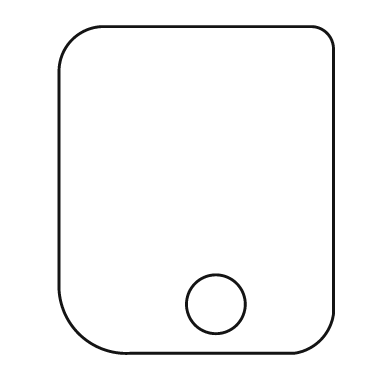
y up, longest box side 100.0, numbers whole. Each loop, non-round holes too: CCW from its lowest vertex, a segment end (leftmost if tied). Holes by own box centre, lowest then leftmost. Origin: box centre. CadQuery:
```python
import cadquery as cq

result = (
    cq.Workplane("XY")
    .moveTo(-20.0, -50.0)
    .lineTo(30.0, -50.0)
    .threePointArc((38.0, -46.0), (42.0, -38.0))
    .lineTo(42.0, 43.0)
    .threePointArc((40.0, 48.0), (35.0, 50.0))
    .lineTo(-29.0, 50.0)
    .threePointArc((-38.0, 46.0), (-42.0, 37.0))
    .lineTo(-42.0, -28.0)
    .threePointArc((-36.0, -44.0), (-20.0, -50.0))
    .close()
    .moveTo(6.0, -35.0)
    .circle(9.0)
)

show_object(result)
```